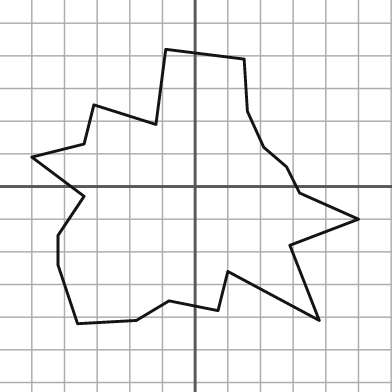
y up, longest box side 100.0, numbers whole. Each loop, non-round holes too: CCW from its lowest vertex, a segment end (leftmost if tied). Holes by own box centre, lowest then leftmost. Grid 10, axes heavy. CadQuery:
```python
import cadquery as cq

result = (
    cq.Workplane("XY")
    .moveTo(-36.0, -42.0)
    .lineTo(-18.0, -41.0)
    .lineTo(-8.0, -35.0)
    .lineTo(7.0, -38.0)
    .lineTo(10.0, -26.0)
    .lineTo(38.0, -41.0)
    .lineTo(29.0, -18.0)
    .lineTo(50.0, -10.0)
    .lineTo(32.0, -2.0)
    .lineTo(28.0, 6.0)
    .lineTo(21.0, 12.0)
    .lineTo(16.0, 23.0)
    .lineTo(15.0, 39.0)
    .lineTo(-9.0, 42.0)
    .lineTo(-12.0, 19.0)
    .lineTo(-31.0, 25.0)
    .lineTo(-34.0, 13.0)
    .lineTo(-50.0, 9.0)
    .lineTo(-34.0, -3.0)
    .lineTo(-42.0, -15.0)
    .lineTo(-42.0, -24.0)
    .close()
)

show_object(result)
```